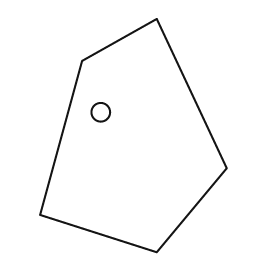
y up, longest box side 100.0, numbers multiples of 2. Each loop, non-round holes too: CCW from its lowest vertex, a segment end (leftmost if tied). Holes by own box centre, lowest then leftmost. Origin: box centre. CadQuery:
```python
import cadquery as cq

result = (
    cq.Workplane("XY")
    .moveTo(10.0, -50.0)
    .lineTo(40.0, -14.0)
    .lineTo(10.0, 50.0)
    .lineTo(-22.0, 32.0)
    .lineTo(-40.0, -34.0)
    .close()
    .moveTo(-14.0, 10.0)
    .circle(4.0)
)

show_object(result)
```